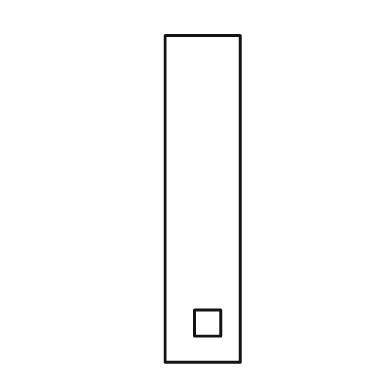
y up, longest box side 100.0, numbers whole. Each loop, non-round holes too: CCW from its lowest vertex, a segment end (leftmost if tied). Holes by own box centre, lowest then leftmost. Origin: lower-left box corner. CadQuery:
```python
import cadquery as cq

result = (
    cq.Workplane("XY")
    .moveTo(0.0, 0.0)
    .lineTo(23.0, 0.0)
    .lineTo(23.0, 100.0)
    .lineTo(0.0, 100.0)
    .close()
    .moveTo(9.0, 8.0)
    .lineTo(17.0, 8.0)
    .lineTo(17.0, 16.0)
    .lineTo(9.0, 16.0)
    .close()
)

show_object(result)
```